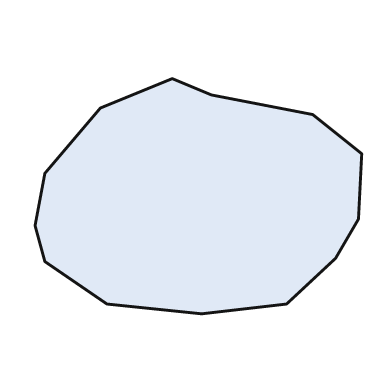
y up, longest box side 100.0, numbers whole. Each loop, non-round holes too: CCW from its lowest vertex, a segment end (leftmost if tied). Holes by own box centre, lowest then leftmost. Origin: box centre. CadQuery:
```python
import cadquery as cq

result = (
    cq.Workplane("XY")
    .moveTo(1.0, -36.0)
    .lineTo(27.0, -33.0)
    .lineTo(42.0, -19.0)
    .lineTo(49.0, -7.0)
    .lineTo(50.0, 13.0)
    .lineTo(35.0, 25.0)
    .lineTo(4.0, 31.0)
    .lineTo(-8.0, 36.0)
    .lineTo(-30.0, 27.0)
    .lineTo(-47.0, 7.0)
    .lineTo(-50.0, -9.0)
    .lineTo(-47.0, -20.0)
    .lineTo(-28.0, -33.0)
    .close()
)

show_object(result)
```